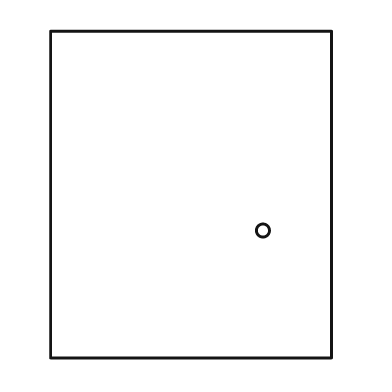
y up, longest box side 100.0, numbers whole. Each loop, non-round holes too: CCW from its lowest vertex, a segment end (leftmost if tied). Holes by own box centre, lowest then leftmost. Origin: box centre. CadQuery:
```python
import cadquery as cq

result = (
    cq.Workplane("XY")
    .moveTo(-43.0, -50.0)
    .lineTo(43.0, -50.0)
    .lineTo(43.0, 50.0)
    .lineTo(-43.0, 50.0)
    .close()
    .moveTo(22.0, -11.0)
    .circle(2.0)
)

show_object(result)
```